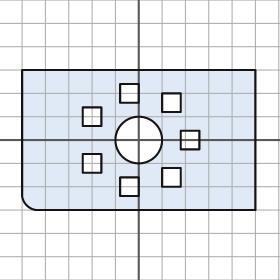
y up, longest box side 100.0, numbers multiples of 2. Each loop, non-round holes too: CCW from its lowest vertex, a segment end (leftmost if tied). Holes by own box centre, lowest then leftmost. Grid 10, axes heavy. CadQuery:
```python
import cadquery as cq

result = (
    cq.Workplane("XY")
    .moveTo(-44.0, -30.0)
    .lineTo(50.0, -30.0)
    .lineTo(50.0, 30.0)
    .lineTo(-50.0, 30.0)
    .lineTo(-50.0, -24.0)
    .threePointArc((-48.0, -28.0), (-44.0, -30.0))
    .close()
    .moveTo(-8.0, -24.0)
    .lineTo(0.0, -24.0)
    .lineTo(0.0, -16.0)
    .lineTo(-8.0, -16.0)
    .close()
    .moveTo(10.0, -20.0)
    .lineTo(18.0, -20.0)
    .lineTo(18.0, -12.0)
    .lineTo(10.0, -12.0)
    .close()
    .moveTo(-24.0, -14.0)
    .lineTo(-16.0, -14.0)
    .lineTo(-16.0, -6.0)
    .lineTo(-24.0, -6.0)
    .close()
    .moveTo(0.0, 0.0)
    .circle(10.0)
    .moveTo(18.0, -4.0)
    .lineTo(26.0, -4.0)
    .lineTo(26.0, 4.0)
    .lineTo(18.0, 4.0)
    .close()
    .moveTo(-24.0, 6.0)
    .lineTo(-16.0, 6.0)
    .lineTo(-16.0, 14.0)
    .lineTo(-24.0, 14.0)
    .close()
    .moveTo(10.0, 12.0)
    .lineTo(18.0, 12.0)
    .lineTo(18.0, 20.0)
    .lineTo(10.0, 20.0)
    .close()
    .moveTo(-8.0, 16.0)
    .lineTo(0.0, 16.0)
    .lineTo(0.0, 24.0)
    .lineTo(-8.0, 24.0)
    .close()
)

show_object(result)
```